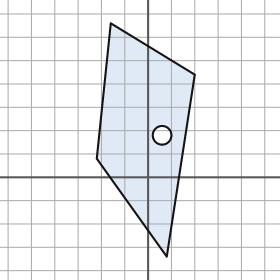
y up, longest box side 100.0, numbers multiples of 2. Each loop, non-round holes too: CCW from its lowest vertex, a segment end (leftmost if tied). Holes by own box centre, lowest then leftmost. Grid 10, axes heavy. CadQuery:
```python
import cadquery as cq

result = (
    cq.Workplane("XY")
    .moveTo(8.0, -34.0)
    .lineTo(20.0, 44.0)
    .lineTo(-16.0, 66.0)
    .lineTo(-22.0, 8.0)
    .close()
    .moveTo(6.0, 18.0)
    .circle(4.0)
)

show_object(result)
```